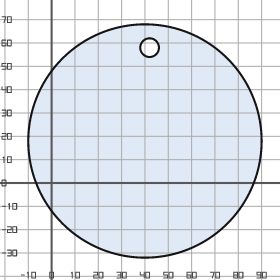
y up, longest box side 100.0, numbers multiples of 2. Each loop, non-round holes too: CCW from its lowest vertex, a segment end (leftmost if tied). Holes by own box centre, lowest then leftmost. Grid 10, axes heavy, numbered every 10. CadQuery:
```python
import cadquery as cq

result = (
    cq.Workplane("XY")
    .moveTo(40.0, 18.0)
    .circle(50.0)
    .moveTo(42.0, 58.0)
    .circle(4.0)
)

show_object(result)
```